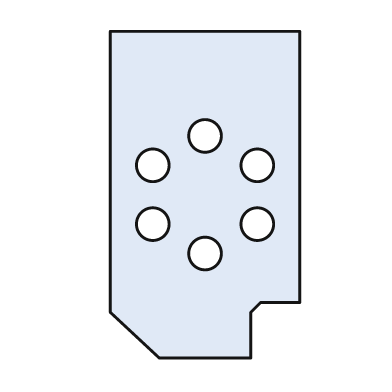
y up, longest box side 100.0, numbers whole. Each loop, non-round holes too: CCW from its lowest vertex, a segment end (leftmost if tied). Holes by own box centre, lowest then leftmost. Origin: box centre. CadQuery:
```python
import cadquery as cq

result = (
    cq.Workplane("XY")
    .moveTo(-14.0, -50.0)
    .lineTo(14.0, -50.0)
    .lineTo(14.0, -36.0)
    .lineTo(17.0, -33.0)
    .lineTo(29.0, -33.0)
    .lineTo(29.0, 50.0)
    .lineTo(-29.0, 50.0)
    .lineTo(-29.0, -36.0)
    .close()
    .moveTo(0.0, -18.0)
    .circle(5.0)
    .moveTo(-16.0, -9.0)
    .circle(5.0)
    .moveTo(16.0, -9.0)
    .circle(5.0)
    .moveTo(-16.0, 9.0)
    .circle(5.0)
    .moveTo(16.0, 9.0)
    .circle(5.0)
    .moveTo(0.0, 18.0)
    .circle(5.0)
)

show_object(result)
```